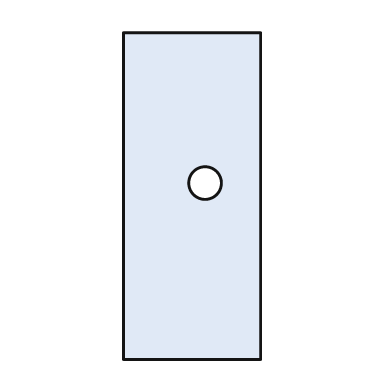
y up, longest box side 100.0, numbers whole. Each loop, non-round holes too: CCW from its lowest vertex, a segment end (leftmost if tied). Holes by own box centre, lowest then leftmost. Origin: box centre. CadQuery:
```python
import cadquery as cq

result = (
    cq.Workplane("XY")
    .moveTo(-21.0, -50.0)
    .lineTo(21.0, -50.0)
    .lineTo(21.0, 50.0)
    .lineTo(-21.0, 50.0)
    .close()
    .moveTo(4.0, 4.0)
    .circle(5.0)
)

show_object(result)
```